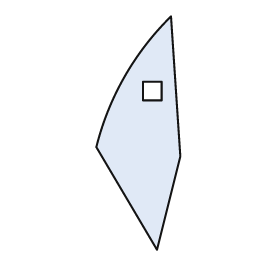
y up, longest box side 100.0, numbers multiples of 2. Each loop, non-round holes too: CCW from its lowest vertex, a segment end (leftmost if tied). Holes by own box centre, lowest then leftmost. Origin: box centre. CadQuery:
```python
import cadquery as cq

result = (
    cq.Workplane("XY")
    .moveTo(8.0, -50.0)
    .lineTo(18.0, -10.0)
    .lineTo(14.0, 50.0)
    .threePointArc((-6.0, 24.0), (-18.0, -6.0))
    .close()
    .moveTo(2.0, 14.0)
    .lineTo(10.0, 14.0)
    .lineTo(10.0, 22.0)
    .lineTo(2.0, 22.0)
    .close()
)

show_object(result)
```